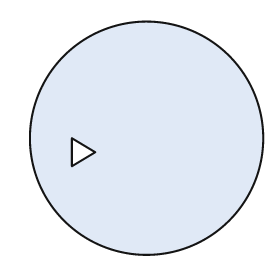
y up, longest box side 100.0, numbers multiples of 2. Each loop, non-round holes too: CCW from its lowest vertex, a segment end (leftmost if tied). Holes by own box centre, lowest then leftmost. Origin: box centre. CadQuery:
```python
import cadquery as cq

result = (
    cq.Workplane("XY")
    .moveTo(0.0, 0.0)
    .circle(50.0)
    .moveTo(-32.0, -12.0)
    .lineTo(-22.0, -6.0)
    .lineTo(-32.0, 0.0)
    .close()
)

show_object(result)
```